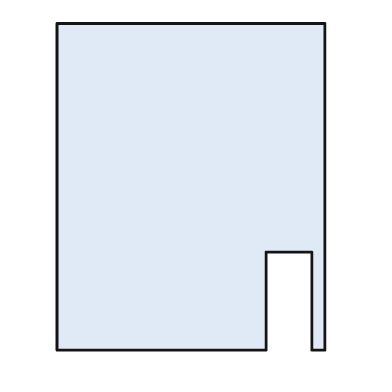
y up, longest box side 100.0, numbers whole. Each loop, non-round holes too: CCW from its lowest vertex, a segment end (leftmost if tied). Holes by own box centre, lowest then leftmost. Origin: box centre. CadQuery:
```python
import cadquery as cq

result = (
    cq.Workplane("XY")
    .moveTo(-41.0, -50.0)
    .lineTo(23.0, -50.0)
    .lineTo(23.0, -20.0)
    .lineTo(37.0, -20.0)
    .lineTo(37.0, -50.0)
    .lineTo(41.0, -50.0)
    .lineTo(41.0, 50.0)
    .lineTo(-41.0, 50.0)
    .close()
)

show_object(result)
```